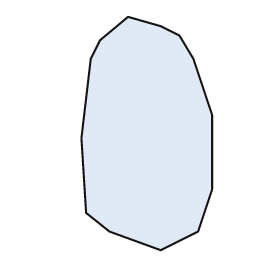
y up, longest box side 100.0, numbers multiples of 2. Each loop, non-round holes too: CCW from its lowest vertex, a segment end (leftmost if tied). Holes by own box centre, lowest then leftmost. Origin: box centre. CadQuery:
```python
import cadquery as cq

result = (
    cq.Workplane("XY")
    .moveTo(6.0, -50.0)
    .lineTo(22.0, -42.0)
    .lineTo(28.0, -24.0)
    .lineTo(28.0, 8.0)
    .lineTo(20.0, 32.0)
    .lineTo(14.0, 42.0)
    .lineTo(6.0, 46.0)
    .lineTo(-8.0, 50.0)
    .lineTo(-20.0, 40.0)
    .lineTo(-24.0, 32.0)
    .lineTo(-28.0, -2.0)
    .lineTo(-26.0, -34.0)
    .lineTo(-16.0, -42.0)
    .close()
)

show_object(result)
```